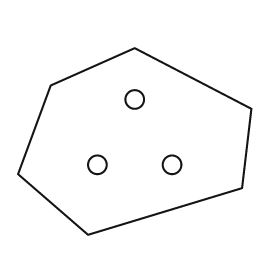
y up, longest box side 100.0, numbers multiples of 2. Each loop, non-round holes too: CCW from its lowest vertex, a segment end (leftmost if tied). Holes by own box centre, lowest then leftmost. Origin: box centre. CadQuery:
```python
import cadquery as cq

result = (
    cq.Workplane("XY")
    .moveTo(-20.0, -40.0)
    .lineTo(46.0, -20.0)
    .lineTo(50.0, 14.0)
    .lineTo(0.0, 40.0)
    .lineTo(-36.0, 24.0)
    .lineTo(-50.0, -14.0)
    .close()
    .moveTo(-16.0, -10.0)
    .circle(4.0)
    .moveTo(16.0, -10.0)
    .circle(4.0)
    .moveTo(0.0, 18.0)
    .circle(4.0)
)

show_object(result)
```